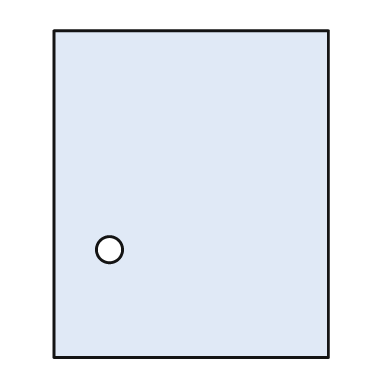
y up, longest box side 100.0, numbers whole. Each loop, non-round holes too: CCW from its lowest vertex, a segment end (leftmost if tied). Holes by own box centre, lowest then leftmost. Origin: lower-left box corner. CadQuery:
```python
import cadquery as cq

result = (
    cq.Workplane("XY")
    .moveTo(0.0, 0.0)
    .lineTo(84.0, 0.0)
    .lineTo(84.0, 100.0)
    .lineTo(0.0, 100.0)
    .close()
    .moveTo(17.0, 33.0)
    .circle(4.0)
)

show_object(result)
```